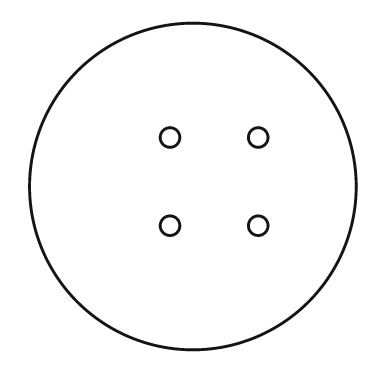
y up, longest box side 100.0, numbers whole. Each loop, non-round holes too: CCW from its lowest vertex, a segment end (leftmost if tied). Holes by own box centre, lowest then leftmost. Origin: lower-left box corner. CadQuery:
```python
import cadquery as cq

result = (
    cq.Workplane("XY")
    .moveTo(50.0, 50.0)
    .circle(50.0)
    .moveTo(43.0, 38.0)
    .circle(3.0)
    .moveTo(70.0, 38.0)
    .circle(3.0)
    .moveTo(43.0, 65.0)
    .circle(3.0)
    .moveTo(70.0, 65.0)
    .circle(3.0)
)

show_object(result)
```